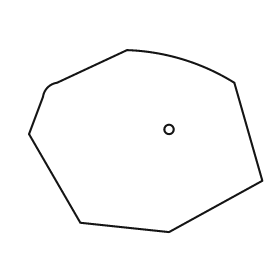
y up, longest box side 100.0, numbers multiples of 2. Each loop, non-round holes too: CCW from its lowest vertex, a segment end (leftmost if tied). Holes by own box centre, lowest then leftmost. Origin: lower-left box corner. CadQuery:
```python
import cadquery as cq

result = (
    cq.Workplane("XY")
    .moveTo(60.0, 0.0)
    .lineTo(100.0, 22.0)
    .lineTo(88.0, 64.0)
    .threePointArc((66.0, 74.0), (42.0, 78.0))
    .lineTo(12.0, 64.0)
    .threePointArc((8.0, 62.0), (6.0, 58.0))
    .lineTo(0.0, 42.0)
    .lineTo(22.0, 4.0)
    .close()
    .moveTo(60.0, 44.0)
    .circle(2.0)
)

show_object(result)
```